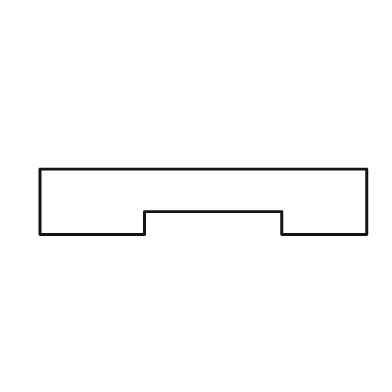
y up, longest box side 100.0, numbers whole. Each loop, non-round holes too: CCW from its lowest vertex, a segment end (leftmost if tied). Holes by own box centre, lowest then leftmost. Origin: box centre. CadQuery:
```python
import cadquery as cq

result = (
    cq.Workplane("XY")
    .moveTo(-50.0, -10.0)
    .lineTo(-18.0, -10.0)
    .lineTo(-18.0, -3.0)
    .lineTo(24.0, -3.0)
    .lineTo(24.0, -10.0)
    .lineTo(50.0, -10.0)
    .lineTo(50.0, 10.0)
    .lineTo(-50.0, 10.0)
    .close()
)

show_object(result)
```